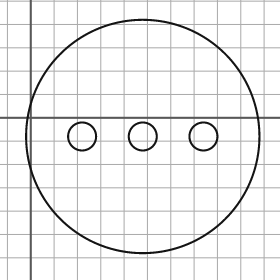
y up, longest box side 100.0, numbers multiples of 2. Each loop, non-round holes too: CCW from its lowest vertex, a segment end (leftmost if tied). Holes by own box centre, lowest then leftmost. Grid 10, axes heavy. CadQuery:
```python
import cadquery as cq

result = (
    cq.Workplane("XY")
    .moveTo(48.0, -8.0)
    .circle(50.0)
    .moveTo(22.0, -8.0)
    .circle(6.0)
    .moveTo(48.0, -8.0)
    .circle(6.0)
    .moveTo(74.0, -8.0)
    .circle(6.0)
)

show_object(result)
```